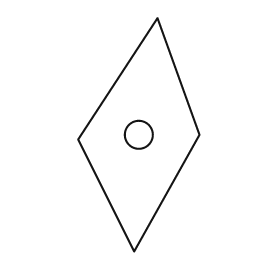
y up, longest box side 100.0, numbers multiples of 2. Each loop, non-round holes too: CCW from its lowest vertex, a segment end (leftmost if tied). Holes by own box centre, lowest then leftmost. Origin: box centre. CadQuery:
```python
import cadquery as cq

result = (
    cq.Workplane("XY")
    .moveTo(-2.0, -50.0)
    .lineTo(26.0, 0.0)
    .lineTo(8.0, 50.0)
    .lineTo(-26.0, -2.0)
    .close()
    .moveTo(0.0, 0.0)
    .circle(6.0)
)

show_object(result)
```